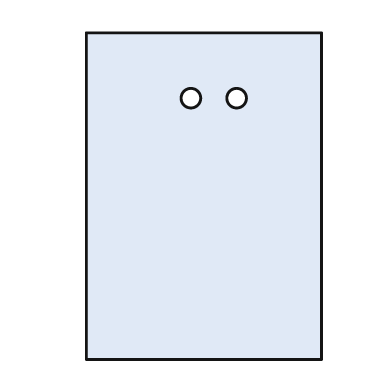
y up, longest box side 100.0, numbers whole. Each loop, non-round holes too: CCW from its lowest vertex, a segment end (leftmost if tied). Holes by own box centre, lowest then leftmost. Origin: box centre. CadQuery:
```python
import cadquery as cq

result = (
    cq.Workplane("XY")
    .moveTo(-36.0, -50.0)
    .lineTo(36.0, -50.0)
    .lineTo(36.0, 50.0)
    .lineTo(-36.0, 50.0)
    .close()
    .moveTo(-4.0, 30.0)
    .circle(3.0)
    .moveTo(10.0, 30.0)
    .circle(3.0)
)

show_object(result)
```